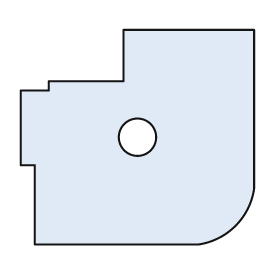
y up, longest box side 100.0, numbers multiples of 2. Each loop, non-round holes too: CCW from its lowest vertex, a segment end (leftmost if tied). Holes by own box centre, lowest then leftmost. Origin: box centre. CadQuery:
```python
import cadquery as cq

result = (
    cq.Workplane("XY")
    .moveTo(-44.0, -46.0)
    .lineTo(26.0, -46.0)
    .threePointArc((42.0, -38.0), (50.0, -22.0))
    .lineTo(50.0, 46.0)
    .lineTo(-6.0, 46.0)
    .lineTo(-6.0, 24.0)
    .lineTo(-38.0, 24.0)
    .lineTo(-38.0, 20.0)
    .lineTo(-50.0, 20.0)
    .lineTo(-50.0, -12.0)
    .lineTo(-44.0, -12.0)
    .close()
    .moveTo(0.0, 0.0)
    .circle(8.0)
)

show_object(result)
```